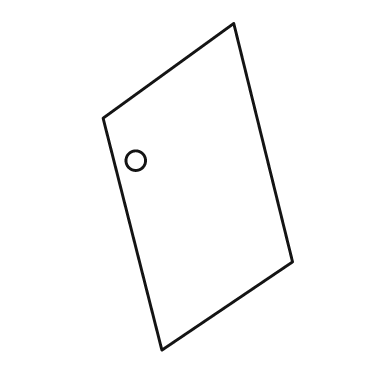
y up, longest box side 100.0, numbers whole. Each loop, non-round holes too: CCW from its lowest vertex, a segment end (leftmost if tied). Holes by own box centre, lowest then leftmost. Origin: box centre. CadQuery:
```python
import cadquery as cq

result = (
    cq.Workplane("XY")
    .moveTo(-11.0, -50.0)
    .lineTo(29.0, -23.0)
    .lineTo(11.0, 50.0)
    .lineTo(-29.0, 21.0)
    .close()
    .moveTo(-19.0, 8.0)
    .circle(3.0)
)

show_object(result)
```